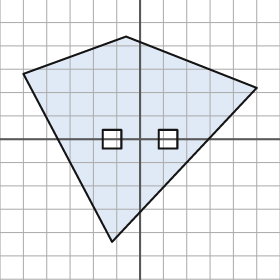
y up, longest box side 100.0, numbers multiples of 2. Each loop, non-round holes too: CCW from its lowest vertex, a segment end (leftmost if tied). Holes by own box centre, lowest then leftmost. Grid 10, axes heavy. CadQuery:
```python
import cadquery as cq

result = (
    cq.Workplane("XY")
    .moveTo(-12.0, -44.0)
    .lineTo(50.0, 22.0)
    .lineTo(-6.0, 44.0)
    .lineTo(-50.0, 28.0)
    .close()
    .moveTo(-16.0, -4.0)
    .lineTo(-8.0, -4.0)
    .lineTo(-8.0, 4.0)
    .lineTo(-16.0, 4.0)
    .close()
    .moveTo(8.0, -4.0)
    .lineTo(16.0, -4.0)
    .lineTo(16.0, 4.0)
    .lineTo(8.0, 4.0)
    .close()
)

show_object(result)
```